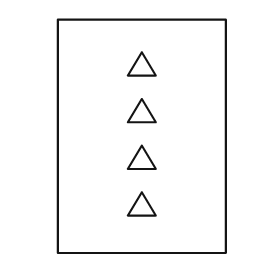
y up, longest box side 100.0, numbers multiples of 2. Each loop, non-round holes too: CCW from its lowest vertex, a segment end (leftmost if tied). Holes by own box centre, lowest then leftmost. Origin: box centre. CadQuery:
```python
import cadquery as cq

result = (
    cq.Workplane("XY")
    .moveTo(-36.0, -50.0)
    .lineTo(36.0, -50.0)
    .lineTo(36.0, 50.0)
    .lineTo(-36.0, 50.0)
    .close()
    .moveTo(-6.0, -34.0)
    .lineTo(6.0, -34.0)
    .lineTo(0.0, -24.0)
    .close()
    .moveTo(-6.0, -14.0)
    .lineTo(6.0, -14.0)
    .lineTo(0.0, -4.0)
    .close()
    .moveTo(-6.0, 6.0)
    .lineTo(6.0, 6.0)
    .lineTo(0.0, 16.0)
    .close()
    .moveTo(-6.0, 26.0)
    .lineTo(6.0, 26.0)
    .lineTo(0.0, 36.0)
    .close()
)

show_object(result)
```